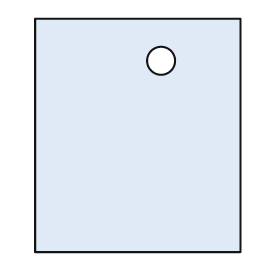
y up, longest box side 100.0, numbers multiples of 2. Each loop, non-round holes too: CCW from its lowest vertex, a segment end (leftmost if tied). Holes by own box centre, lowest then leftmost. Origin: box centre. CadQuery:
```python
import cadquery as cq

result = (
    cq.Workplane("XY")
    .moveTo(-44.0, -50.0)
    .lineTo(44.0, -50.0)
    .lineTo(44.0, 50.0)
    .lineTo(-44.0, 50.0)
    .close()
    .moveTo(10.0, 32.0)
    .circle(6.0)
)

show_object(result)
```